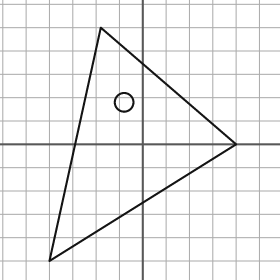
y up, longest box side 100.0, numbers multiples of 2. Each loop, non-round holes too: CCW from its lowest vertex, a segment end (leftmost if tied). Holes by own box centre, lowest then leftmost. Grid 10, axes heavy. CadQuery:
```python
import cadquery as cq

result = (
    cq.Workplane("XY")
    .moveTo(-40.0, -50.0)
    .lineTo(40.0, 0.0)
    .lineTo(-18.0, 50.0)
    .close()
    .moveTo(-8.0, 18.0)
    .circle(4.0)
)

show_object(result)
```